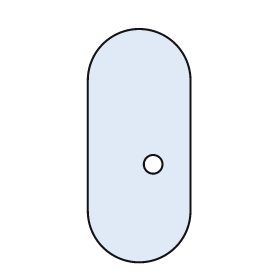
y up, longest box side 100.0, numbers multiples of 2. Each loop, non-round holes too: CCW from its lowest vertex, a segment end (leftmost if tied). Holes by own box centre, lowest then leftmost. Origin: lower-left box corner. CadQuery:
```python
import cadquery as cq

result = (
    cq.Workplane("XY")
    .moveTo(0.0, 22.0)
    .threePointArc((22.0, 0.0), (44.0, 22.0))
    .lineTo(44.0, 78.0)
    .threePointArc((22.0, 100.0), (0.0, 78.0))
    .close()
    .moveTo(28.0, 42.0)
    .circle(4.0)
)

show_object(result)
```